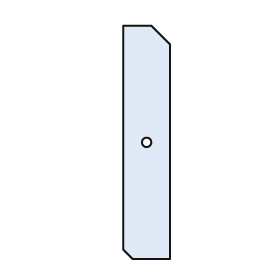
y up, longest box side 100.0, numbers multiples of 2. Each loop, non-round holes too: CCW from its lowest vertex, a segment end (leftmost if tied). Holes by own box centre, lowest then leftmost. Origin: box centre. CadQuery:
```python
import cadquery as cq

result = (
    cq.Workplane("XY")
    .moveTo(-6.0, -50.0)
    .lineTo(10.0, -50.0)
    .lineTo(10.0, 42.0)
    .lineTo(2.0, 50.0)
    .lineTo(-10.0, 50.0)
    .lineTo(-10.0, -46.0)
    .close()
    .moveTo(0.0, 0.0)
    .circle(2.0)
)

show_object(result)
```